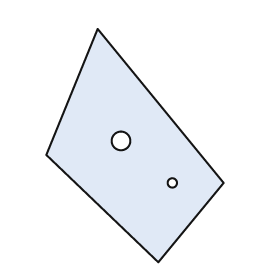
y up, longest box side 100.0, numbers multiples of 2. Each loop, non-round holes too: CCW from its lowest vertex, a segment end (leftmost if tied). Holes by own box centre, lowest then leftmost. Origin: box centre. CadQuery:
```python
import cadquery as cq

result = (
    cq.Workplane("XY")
    .moveTo(10.0, -50.0)
    .lineTo(38.0, -16.0)
    .lineTo(-16.0, 50.0)
    .lineTo(-38.0, -4.0)
    .close()
    .moveTo(16.0, -16.0)
    .circle(2.0)
    .moveTo(-6.0, 2.0)
    .circle(4.0)
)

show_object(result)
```